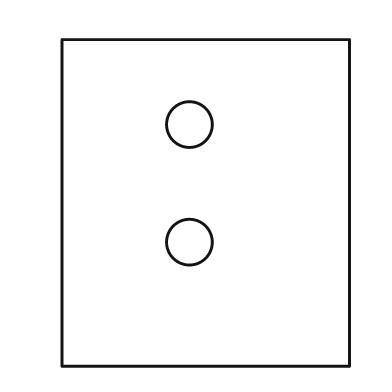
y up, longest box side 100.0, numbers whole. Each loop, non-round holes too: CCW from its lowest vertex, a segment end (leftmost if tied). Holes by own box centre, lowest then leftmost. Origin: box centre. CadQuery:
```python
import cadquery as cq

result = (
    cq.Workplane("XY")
    .moveTo(-44.0, -50.0)
    .lineTo(44.0, -50.0)
    .lineTo(44.0, 50.0)
    .lineTo(-44.0, 50.0)
    .close()
    .moveTo(-5.0, -12.0)
    .circle(7.0)
    .moveTo(-5.0, 24.0)
    .circle(7.0)
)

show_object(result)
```